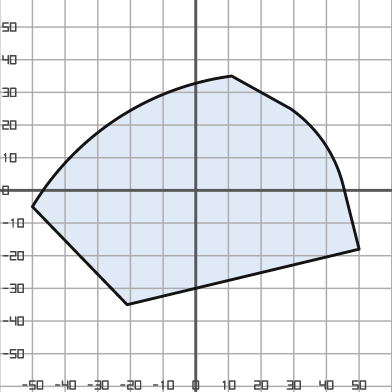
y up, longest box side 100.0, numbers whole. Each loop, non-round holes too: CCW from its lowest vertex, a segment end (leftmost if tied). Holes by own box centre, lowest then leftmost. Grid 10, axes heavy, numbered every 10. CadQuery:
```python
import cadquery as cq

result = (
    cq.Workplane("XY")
    .moveTo(-21.0, -35.0)
    .lineTo(50.0, -18.0)
    .lineTo(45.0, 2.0)
    .threePointArc((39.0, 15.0), (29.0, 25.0))
    .lineTo(11.0, 35.0)
    .threePointArc((-24.0, 22.0), (-50.0, -5.0))
    .close()
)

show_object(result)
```